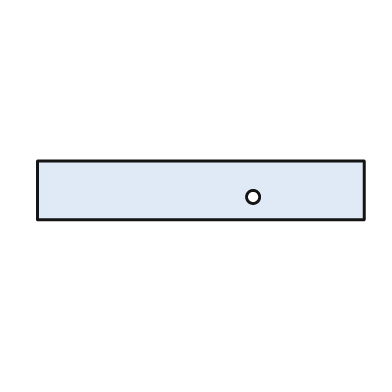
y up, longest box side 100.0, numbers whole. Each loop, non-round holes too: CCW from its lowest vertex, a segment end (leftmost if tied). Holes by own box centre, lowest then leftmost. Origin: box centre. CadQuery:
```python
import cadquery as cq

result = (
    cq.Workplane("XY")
    .moveTo(-50.0, -9.0)
    .lineTo(50.0, -9.0)
    .lineTo(50.0, 9.0)
    .lineTo(-50.0, 9.0)
    .close()
    .moveTo(16.0, -2.0)
    .circle(2.0)
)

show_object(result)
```